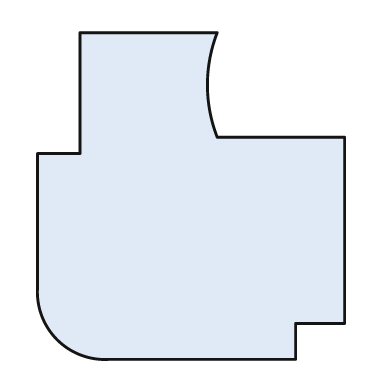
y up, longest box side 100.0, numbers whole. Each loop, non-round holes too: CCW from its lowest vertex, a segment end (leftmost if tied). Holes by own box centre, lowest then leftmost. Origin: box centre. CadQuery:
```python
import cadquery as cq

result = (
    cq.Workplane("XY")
    .moveTo(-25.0, -50.0)
    .lineTo(32.0, -50.0)
    .lineTo(32.0, -39.0)
    .lineTo(47.0, -39.0)
    .lineTo(47.0, 18.0)
    .lineTo(8.0, 18.0)
    .threePointArc((5.0, 34.0), (8.0, 50.0))
    .lineTo(-34.0, 50.0)
    .lineTo(-34.0, 13.0)
    .lineTo(-47.0, 13.0)
    .lineTo(-47.0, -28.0)
    .threePointArc((-41.0, -44.0), (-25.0, -50.0))
    .close()
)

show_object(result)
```